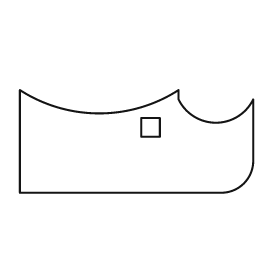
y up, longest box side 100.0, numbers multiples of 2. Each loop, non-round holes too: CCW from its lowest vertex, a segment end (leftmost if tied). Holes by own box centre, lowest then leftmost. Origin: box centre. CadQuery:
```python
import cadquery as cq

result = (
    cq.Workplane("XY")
    .moveTo(-50.0, -22.0)
    .lineTo(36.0, -22.0)
    .threePointArc((46.0, -18.0), (50.0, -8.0))
    .lineTo(50.0, 18.0)
    .threePointArc((34.0, 8.0), (18.0, 18.0))
    .lineTo(18.0, 22.0)
    .threePointArc((-16.0, 12.0), (-50.0, 22.0))
    .close()
    .moveTo(2.0, 2.0)
    .lineTo(10.0, 2.0)
    .lineTo(10.0, 10.0)
    .lineTo(2.0, 10.0)
    .close()
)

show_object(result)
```